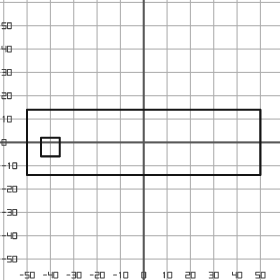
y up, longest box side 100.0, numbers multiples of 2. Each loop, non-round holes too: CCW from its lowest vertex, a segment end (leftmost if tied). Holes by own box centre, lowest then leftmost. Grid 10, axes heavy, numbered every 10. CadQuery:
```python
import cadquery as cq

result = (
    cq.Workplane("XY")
    .moveTo(-50.0, -14.0)
    .lineTo(50.0, -14.0)
    .lineTo(50.0, 14.0)
    .lineTo(-50.0, 14.0)
    .close()
    .moveTo(-44.0, -6.0)
    .lineTo(-36.0, -6.0)
    .lineTo(-36.0, 2.0)
    .lineTo(-44.0, 2.0)
    .close()
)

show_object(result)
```